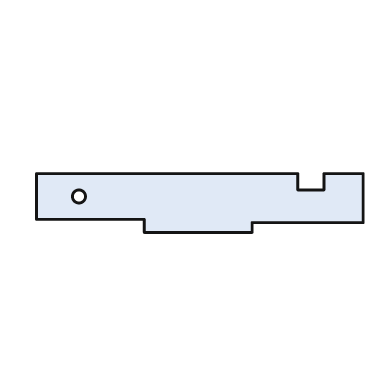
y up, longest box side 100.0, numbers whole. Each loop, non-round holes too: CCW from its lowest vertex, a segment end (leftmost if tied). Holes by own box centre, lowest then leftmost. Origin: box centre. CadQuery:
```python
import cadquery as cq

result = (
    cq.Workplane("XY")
    .moveTo(-17.0, -9.0)
    .lineTo(16.0, -9.0)
    .lineTo(16.0, -6.0)
    .lineTo(50.0, -6.0)
    .lineTo(50.0, 9.0)
    .lineTo(38.0, 9.0)
    .lineTo(38.0, 4.0)
    .lineTo(30.0, 4.0)
    .lineTo(30.0, 9.0)
    .lineTo(-50.0, 9.0)
    .lineTo(-50.0, -5.0)
    .lineTo(-17.0, -5.0)
    .close()
    .moveTo(-37.0, 2.0)
    .circle(2.0)
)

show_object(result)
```